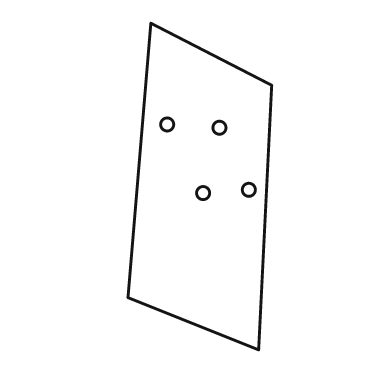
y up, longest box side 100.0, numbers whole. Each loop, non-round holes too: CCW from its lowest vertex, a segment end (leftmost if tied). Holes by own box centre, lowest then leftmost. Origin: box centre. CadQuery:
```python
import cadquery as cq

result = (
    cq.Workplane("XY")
    .moveTo(18.0, -50.0)
    .lineTo(22.0, 31.0)
    .lineTo(-15.0, 50.0)
    .lineTo(-22.0, -34.0)
    .close()
    .moveTo(1.0, -2.0)
    .circle(2.0)
    .moveTo(15.0, -1.0)
    .circle(2.0)
    .moveTo(6.0, 18.0)
    .circle(2.0)
    .moveTo(-10.0, 19.0)
    .circle(2.0)
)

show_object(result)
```